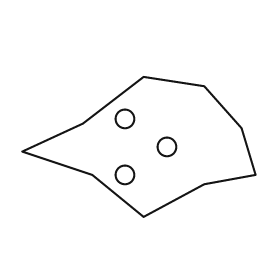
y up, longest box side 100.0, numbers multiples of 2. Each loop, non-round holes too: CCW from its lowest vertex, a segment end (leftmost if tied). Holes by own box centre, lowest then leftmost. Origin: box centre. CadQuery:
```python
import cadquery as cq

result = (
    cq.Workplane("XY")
    .moveTo(2.0, -30.0)
    .lineTo(28.0, -16.0)
    .lineTo(50.0, -12.0)
    .lineTo(44.0, 8.0)
    .lineTo(28.0, 26.0)
    .lineTo(2.0, 30.0)
    .lineTo(-24.0, 10.0)
    .lineTo(-50.0, -2.0)
    .lineTo(-20.0, -12.0)
    .close()
    .moveTo(-6.0, -12.0)
    .circle(4.0)
    .moveTo(12.0, 0.0)
    .circle(4.0)
    .moveTo(-6.0, 12.0)
    .circle(4.0)
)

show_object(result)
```